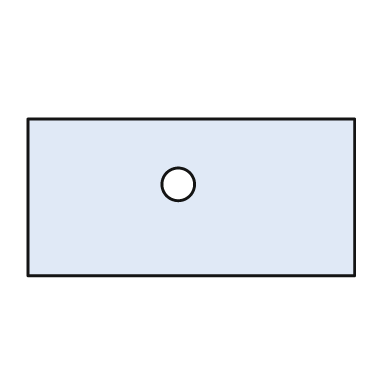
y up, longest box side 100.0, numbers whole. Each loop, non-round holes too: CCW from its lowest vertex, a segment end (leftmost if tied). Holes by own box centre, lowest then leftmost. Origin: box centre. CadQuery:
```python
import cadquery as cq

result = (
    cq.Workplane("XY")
    .moveTo(-50.0, -24.0)
    .lineTo(50.0, -24.0)
    .lineTo(50.0, 24.0)
    .lineTo(-50.0, 24.0)
    .close()
    .moveTo(-4.0, 4.0)
    .circle(5.0)
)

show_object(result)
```